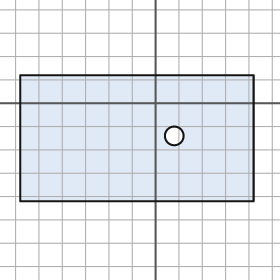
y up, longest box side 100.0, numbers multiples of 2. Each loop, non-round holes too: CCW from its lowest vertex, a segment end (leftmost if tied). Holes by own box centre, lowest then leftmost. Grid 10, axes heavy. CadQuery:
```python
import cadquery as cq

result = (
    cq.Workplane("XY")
    .moveTo(-58.0, -42.0)
    .lineTo(42.0, -42.0)
    .lineTo(42.0, 12.0)
    .lineTo(-58.0, 12.0)
    .close()
    .moveTo(8.0, -14.0)
    .circle(4.0)
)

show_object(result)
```